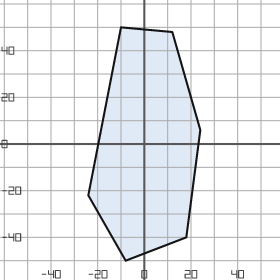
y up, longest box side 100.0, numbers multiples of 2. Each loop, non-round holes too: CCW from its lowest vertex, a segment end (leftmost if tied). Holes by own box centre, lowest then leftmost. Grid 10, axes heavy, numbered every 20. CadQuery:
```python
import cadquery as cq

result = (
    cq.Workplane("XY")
    .moveTo(-8.0, -50.0)
    .lineTo(18.0, -40.0)
    .lineTo(24.0, 6.0)
    .lineTo(12.0, 48.0)
    .lineTo(-10.0, 50.0)
    .lineTo(-24.0, -22.0)
    .close()
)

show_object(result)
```